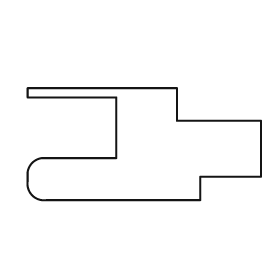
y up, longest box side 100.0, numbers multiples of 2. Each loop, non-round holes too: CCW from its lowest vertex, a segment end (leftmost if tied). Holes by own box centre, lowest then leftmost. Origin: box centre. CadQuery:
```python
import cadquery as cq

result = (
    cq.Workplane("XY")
    .moveTo(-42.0, -24.0)
    .lineTo(24.0, -24.0)
    .lineTo(24.0, -14.0)
    .lineTo(50.0, -14.0)
    .lineTo(50.0, 10.0)
    .lineTo(14.0, 10.0)
    .lineTo(14.0, 24.0)
    .lineTo(-50.0, 24.0)
    .lineTo(-50.0, 20.0)
    .lineTo(-12.0, 20.0)
    .lineTo(-12.0, -6.0)
    .lineTo(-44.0, -6.0)
    .threePointArc((-48.0, -8.0), (-50.0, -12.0))
    .lineTo(-50.0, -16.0)
    .threePointArc((-48.0, -22.0), (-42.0, -24.0))
    .close()
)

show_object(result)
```